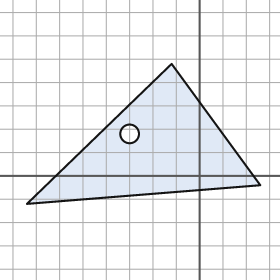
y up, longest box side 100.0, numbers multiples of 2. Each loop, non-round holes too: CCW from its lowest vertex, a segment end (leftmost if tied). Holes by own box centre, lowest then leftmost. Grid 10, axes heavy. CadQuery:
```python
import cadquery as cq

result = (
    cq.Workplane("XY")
    .moveTo(-74.0, -12.0)
    .lineTo(26.0, -4.0)
    .lineTo(-12.0, 48.0)
    .close()
    .moveTo(-30.0, 18.0)
    .circle(4.0)
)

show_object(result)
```